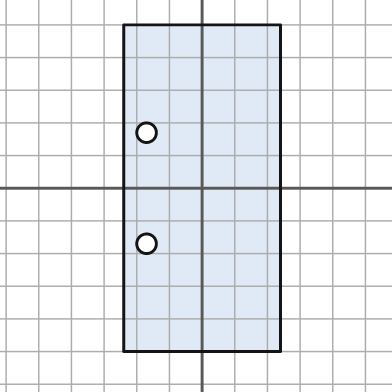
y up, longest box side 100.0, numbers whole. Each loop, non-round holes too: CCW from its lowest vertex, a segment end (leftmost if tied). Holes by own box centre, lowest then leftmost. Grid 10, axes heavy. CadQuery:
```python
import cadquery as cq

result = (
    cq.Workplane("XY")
    .moveTo(-24.0, -50.0)
    .lineTo(24.0, -50.0)
    .lineTo(24.0, 50.0)
    .lineTo(-24.0, 50.0)
    .close()
    .moveTo(-17.0, -17.0)
    .circle(3.0)
    .moveTo(-17.0, 17.0)
    .circle(3.0)
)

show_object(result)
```